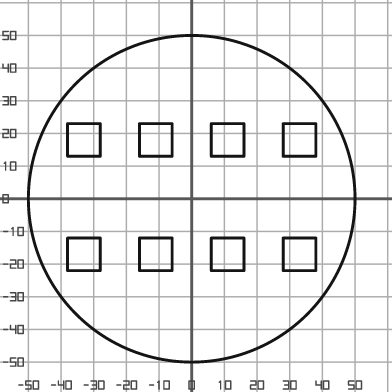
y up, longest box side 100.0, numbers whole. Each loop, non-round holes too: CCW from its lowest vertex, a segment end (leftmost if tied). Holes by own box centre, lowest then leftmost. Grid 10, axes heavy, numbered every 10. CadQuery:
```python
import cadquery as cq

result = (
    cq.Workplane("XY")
    .moveTo(0.0, 0.0)
    .circle(50.0)
    .moveTo(-38.0, -22.0)
    .lineTo(-28.0, -22.0)
    .lineTo(-28.0, -12.0)
    .lineTo(-38.0, -12.0)
    .close()
    .moveTo(-16.0, -22.0)
    .lineTo(-6.0, -22.0)
    .lineTo(-6.0, -12.0)
    .lineTo(-16.0, -12.0)
    .close()
    .moveTo(6.0, -22.0)
    .lineTo(16.0, -22.0)
    .lineTo(16.0, -12.0)
    .lineTo(6.0, -12.0)
    .close()
    .moveTo(28.0, -22.0)
    .lineTo(38.0, -22.0)
    .lineTo(38.0, -12.0)
    .lineTo(28.0, -12.0)
    .close()
    .moveTo(-38.0, 13.0)
    .lineTo(-28.0, 13.0)
    .lineTo(-28.0, 23.0)
    .lineTo(-38.0, 23.0)
    .close()
    .moveTo(-16.0, 13.0)
    .lineTo(-6.0, 13.0)
    .lineTo(-6.0, 23.0)
    .lineTo(-16.0, 23.0)
    .close()
    .moveTo(6.0, 13.0)
    .lineTo(16.0, 13.0)
    .lineTo(16.0, 23.0)
    .lineTo(6.0, 23.0)
    .close()
    .moveTo(28.0, 13.0)
    .lineTo(38.0, 13.0)
    .lineTo(38.0, 23.0)
    .lineTo(28.0, 23.0)
    .close()
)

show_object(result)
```